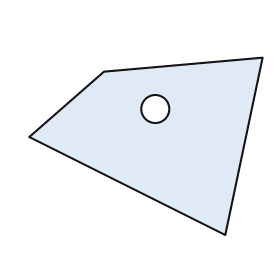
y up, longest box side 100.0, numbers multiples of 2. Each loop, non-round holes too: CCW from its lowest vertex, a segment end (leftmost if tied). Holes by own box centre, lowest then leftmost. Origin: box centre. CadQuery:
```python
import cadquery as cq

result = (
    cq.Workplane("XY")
    .moveTo(34.0, -38.0)
    .lineTo(50.0, 38.0)
    .lineTo(-18.0, 32.0)
    .lineTo(-50.0, 4.0)
    .close()
    .moveTo(4.0, 16.0)
    .circle(6.0)
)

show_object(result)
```